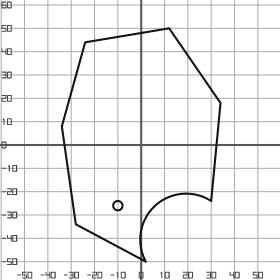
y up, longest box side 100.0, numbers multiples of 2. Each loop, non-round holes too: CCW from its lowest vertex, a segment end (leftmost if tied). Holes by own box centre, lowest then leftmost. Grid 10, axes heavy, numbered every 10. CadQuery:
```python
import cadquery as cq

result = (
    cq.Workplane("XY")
    .moveTo(2.0, -50.0)
    .threePointArc((6.0, -26.0), (30.0, -24.0))
    .lineTo(34.0, 18.0)
    .lineTo(12.0, 50.0)
    .lineTo(-24.0, 44.0)
    .lineTo(-34.0, 8.0)
    .lineTo(-28.0, -34.0)
    .close()
    .moveTo(-10.0, -26.0)
    .circle(2.0)
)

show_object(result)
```